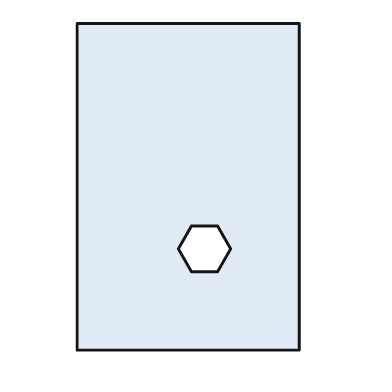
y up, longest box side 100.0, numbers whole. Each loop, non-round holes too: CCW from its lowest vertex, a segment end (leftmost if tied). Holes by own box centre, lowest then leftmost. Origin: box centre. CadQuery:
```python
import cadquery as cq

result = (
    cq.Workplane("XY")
    .moveTo(-34.0, -50.0)
    .lineTo(34.0, -50.0)
    .lineTo(34.0, 50.0)
    .lineTo(-34.0, 50.0)
    .close()
    .moveTo(1.0, -26.0)
    .lineTo(9.0, -26.0)
    .lineTo(13.0, -19.0)
    .lineTo(9.0, -12.0)
    .lineTo(1.0, -12.0)
    .lineTo(-3.0, -19.0)
    .close()
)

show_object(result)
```